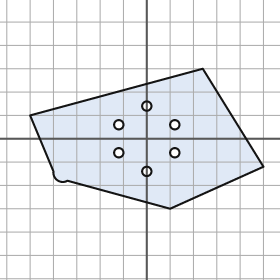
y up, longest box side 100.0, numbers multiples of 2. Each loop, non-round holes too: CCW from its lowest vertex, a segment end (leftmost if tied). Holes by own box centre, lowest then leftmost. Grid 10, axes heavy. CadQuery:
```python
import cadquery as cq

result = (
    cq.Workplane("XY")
    .moveTo(10.0, -30.0)
    .lineTo(50.0, -12.0)
    .lineTo(24.0, 30.0)
    .lineTo(-50.0, 10.0)
    .lineTo(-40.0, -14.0)
    .threePointArc((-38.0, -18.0), (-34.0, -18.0))
    .close()
    .moveTo(0.0, -14.0)
    .circle(2.0)
    .moveTo(-12.0, -6.0)
    .circle(2.0)
    .moveTo(12.0, -6.0)
    .circle(2.0)
    .moveTo(-12.0, 6.0)
    .circle(2.0)
    .moveTo(12.0, 6.0)
    .circle(2.0)
    .moveTo(0.0, 14.0)
    .circle(2.0)
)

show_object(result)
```